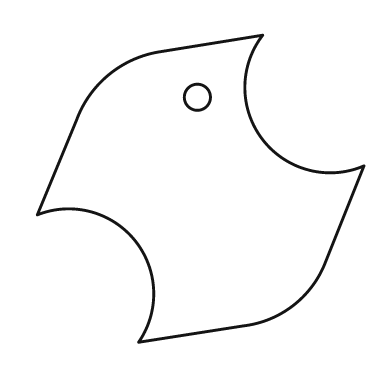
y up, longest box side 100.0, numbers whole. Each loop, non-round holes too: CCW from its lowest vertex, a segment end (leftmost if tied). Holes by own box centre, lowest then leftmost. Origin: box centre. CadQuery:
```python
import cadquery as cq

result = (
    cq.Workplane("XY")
    .moveTo(-19.0, -47.0)
    .lineTo(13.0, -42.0)
    .threePointArc((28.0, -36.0), (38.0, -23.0))
    .lineTo(50.0, 7.0)
    .threePointArc((19.0, 15.0), (19.0, 47.0))
    .lineTo(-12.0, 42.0)
    .threePointArc((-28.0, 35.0), (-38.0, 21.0))
    .lineTo(-50.0, -8.0)
    .threePointArc((-20.0, -16.0), (-19.0, -47.0))
    .close()
    .moveTo(-1.0, 28.0)
    .circle(4.0)
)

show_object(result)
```